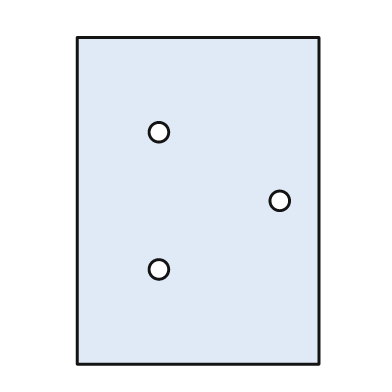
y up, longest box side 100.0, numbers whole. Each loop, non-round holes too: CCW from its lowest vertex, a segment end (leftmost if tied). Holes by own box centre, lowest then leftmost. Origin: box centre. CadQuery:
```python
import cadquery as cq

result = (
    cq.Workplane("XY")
    .moveTo(-37.0, -50.0)
    .lineTo(37.0, -50.0)
    .lineTo(37.0, 50.0)
    .lineTo(-37.0, 50.0)
    .close()
    .moveTo(-12.0, -21.0)
    .circle(3.0)
    .moveTo(25.0, 0.0)
    .circle(3.0)
    .moveTo(-12.0, 21.0)
    .circle(3.0)
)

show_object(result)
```